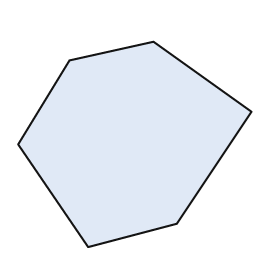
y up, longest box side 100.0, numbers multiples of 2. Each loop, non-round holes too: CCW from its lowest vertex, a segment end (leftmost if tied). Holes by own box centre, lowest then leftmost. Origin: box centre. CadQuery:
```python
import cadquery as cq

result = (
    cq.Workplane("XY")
    .moveTo(-20.0, -44.0)
    .lineTo(18.0, -34.0)
    .lineTo(50.0, 14.0)
    .lineTo(8.0, 44.0)
    .lineTo(-28.0, 36.0)
    .lineTo(-50.0, 0.0)
    .close()
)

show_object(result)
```